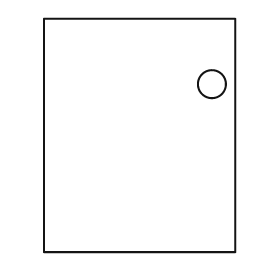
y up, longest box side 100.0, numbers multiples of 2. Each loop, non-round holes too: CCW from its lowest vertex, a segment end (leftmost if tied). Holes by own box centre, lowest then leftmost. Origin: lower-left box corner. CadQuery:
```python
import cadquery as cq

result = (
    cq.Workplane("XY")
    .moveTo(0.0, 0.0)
    .lineTo(82.0, 0.0)
    .lineTo(82.0, 100.0)
    .lineTo(0.0, 100.0)
    .close()
    .moveTo(72.0, 72.0)
    .circle(6.0)
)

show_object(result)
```